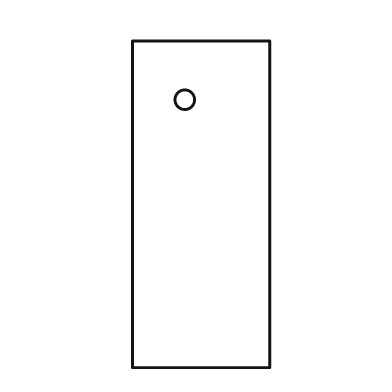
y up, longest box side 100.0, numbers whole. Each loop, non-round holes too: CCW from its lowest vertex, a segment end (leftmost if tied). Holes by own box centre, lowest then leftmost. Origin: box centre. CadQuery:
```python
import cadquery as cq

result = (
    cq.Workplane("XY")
    .moveTo(-21.0, -50.0)
    .lineTo(21.0, -50.0)
    .lineTo(21.0, 50.0)
    .lineTo(-21.0, 50.0)
    .close()
    .moveTo(-5.0, 32.0)
    .circle(3.0)
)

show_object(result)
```